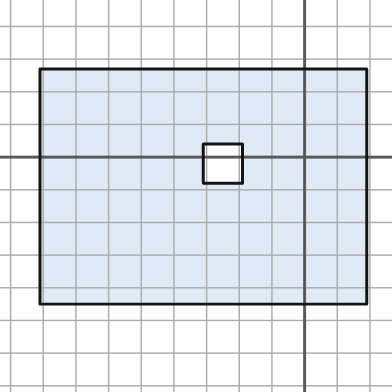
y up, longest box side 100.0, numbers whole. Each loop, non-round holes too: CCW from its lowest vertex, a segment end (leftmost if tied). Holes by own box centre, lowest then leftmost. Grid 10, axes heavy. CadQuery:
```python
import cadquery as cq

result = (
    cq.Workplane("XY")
    .moveTo(-81.0, -45.0)
    .lineTo(19.0, -45.0)
    .lineTo(19.0, 27.0)
    .lineTo(-81.0, 27.0)
    .close()
    .moveTo(-31.0, -8.0)
    .lineTo(-19.0, -8.0)
    .lineTo(-19.0, 4.0)
    .lineTo(-31.0, 4.0)
    .close()
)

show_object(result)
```